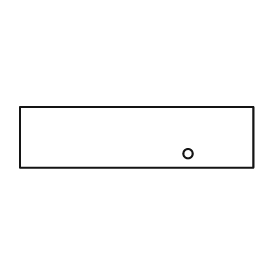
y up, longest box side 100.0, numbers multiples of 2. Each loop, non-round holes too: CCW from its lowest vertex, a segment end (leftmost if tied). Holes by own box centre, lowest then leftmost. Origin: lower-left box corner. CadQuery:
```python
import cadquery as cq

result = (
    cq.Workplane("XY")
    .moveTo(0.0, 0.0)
    .lineTo(100.0, 0.0)
    .lineTo(100.0, 26.0)
    .lineTo(0.0, 26.0)
    .close()
    .moveTo(72.0, 6.0)
    .circle(2.0)
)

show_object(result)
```